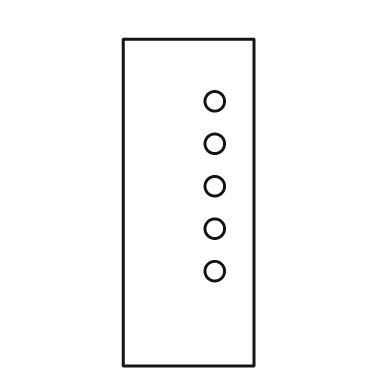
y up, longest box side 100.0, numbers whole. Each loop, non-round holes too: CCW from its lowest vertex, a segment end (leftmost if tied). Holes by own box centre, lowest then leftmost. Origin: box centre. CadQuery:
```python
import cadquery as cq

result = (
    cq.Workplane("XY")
    .moveTo(-20.0, -50.0)
    .lineTo(20.0, -50.0)
    .lineTo(20.0, 50.0)
    .lineTo(-20.0, 50.0)
    .close()
    .moveTo(8.0, -21.0)
    .circle(3.0)
    .moveTo(8.0, -8.0)
    .circle(3.0)
    .moveTo(8.0, 5.0)
    .circle(3.0)
    .moveTo(8.0, 18.0)
    .circle(3.0)
    .moveTo(8.0, 31.0)
    .circle(3.0)
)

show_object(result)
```